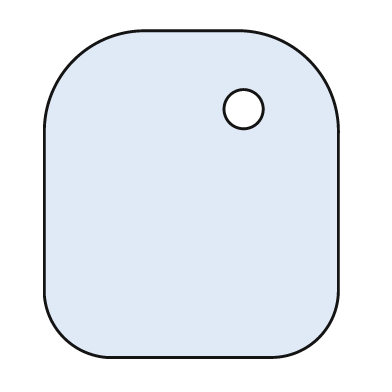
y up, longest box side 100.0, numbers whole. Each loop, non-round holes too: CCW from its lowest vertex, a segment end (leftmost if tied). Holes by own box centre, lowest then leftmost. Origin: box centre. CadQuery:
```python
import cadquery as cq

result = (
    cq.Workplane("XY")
    .moveTo(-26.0, -50.0)
    .lineTo(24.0, -50.0)
    .threePointArc((39.0, -44.0), (45.0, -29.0))
    .lineTo(45.0, 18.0)
    .threePointArc((36.0, 41.0), (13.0, 50.0))
    .lineTo(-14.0, 50.0)
    .threePointArc((-36.0, 41.0), (-45.0, 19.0))
    .lineTo(-45.0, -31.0)
    .threePointArc((-39.0, -44.0), (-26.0, -50.0))
    .close()
    .moveTo(16.0, 26.0)
    .circle(6.0)
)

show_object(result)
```